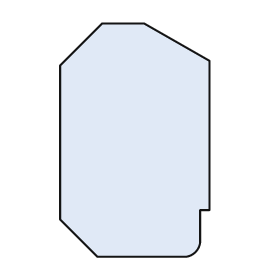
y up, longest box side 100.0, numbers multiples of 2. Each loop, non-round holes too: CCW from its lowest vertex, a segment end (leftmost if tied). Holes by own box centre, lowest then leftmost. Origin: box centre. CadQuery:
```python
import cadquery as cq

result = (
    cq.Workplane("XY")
    .moveTo(-16.0, -50.0)
    .lineTo(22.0, -50.0)
    .threePointArc((26.0, -48.0), (28.0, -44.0))
    .lineTo(28.0, -30.0)
    .lineTo(32.0, -30.0)
    .lineTo(32.0, 34.0)
    .lineTo(4.0, 50.0)
    .lineTo(-14.0, 50.0)
    .lineTo(-32.0, 32.0)
    .lineTo(-32.0, -34.0)
    .close()
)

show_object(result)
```